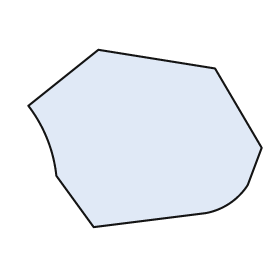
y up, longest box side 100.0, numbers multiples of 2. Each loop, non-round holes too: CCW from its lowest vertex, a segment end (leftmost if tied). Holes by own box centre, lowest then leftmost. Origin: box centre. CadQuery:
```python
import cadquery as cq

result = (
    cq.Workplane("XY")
    .moveTo(-22.0, -38.0)
    .lineTo(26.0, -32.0)
    .threePointArc((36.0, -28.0), (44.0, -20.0))
    .lineTo(50.0, -4.0)
    .lineTo(30.0, 30.0)
    .lineTo(-20.0, 38.0)
    .lineTo(-50.0, 14.0)
    .threePointArc((-42.0, 0.0), (-38.0, -16.0))
    .close()
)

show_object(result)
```